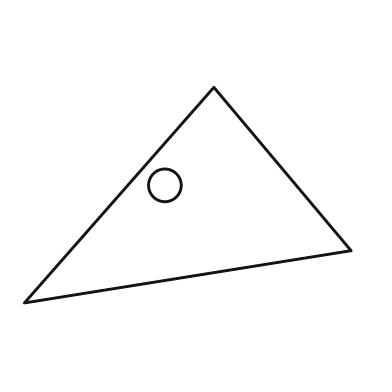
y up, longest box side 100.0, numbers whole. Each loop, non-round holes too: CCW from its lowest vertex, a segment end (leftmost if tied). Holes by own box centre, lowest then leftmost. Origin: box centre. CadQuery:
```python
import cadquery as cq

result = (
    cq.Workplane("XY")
    .moveTo(-50.0, -33.0)
    .lineTo(50.0, -17.0)
    .lineTo(8.0, 33.0)
    .close()
    .moveTo(-7.0, 3.0)
    .circle(5.0)
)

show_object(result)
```